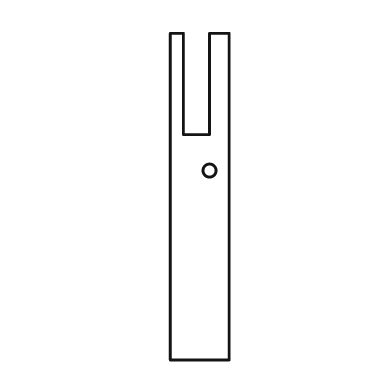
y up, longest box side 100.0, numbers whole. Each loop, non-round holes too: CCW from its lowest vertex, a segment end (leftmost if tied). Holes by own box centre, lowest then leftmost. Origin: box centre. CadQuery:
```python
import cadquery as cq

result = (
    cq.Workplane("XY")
    .moveTo(-9.0, -50.0)
    .lineTo(9.0, -50.0)
    .lineTo(9.0, 50.0)
    .lineTo(3.0, 50.0)
    .lineTo(3.0, 19.0)
    .lineTo(-5.0, 19.0)
    .lineTo(-5.0, 50.0)
    .lineTo(-9.0, 50.0)
    .close()
    .moveTo(3.0, 8.0)
    .circle(2.0)
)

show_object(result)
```